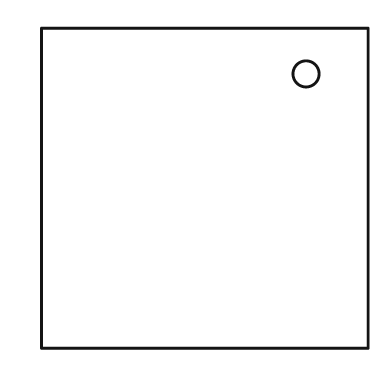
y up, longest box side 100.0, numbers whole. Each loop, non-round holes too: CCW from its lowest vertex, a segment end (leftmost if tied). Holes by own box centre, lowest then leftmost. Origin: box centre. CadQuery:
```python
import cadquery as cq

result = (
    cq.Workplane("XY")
    .moveTo(-50.0, -49.0)
    .lineTo(50.0, -49.0)
    .lineTo(50.0, 49.0)
    .lineTo(-50.0, 49.0)
    .close()
    .moveTo(31.0, 35.0)
    .circle(4.0)
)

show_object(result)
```